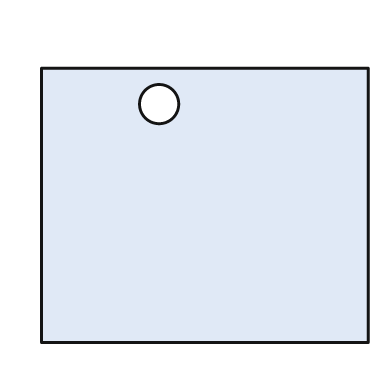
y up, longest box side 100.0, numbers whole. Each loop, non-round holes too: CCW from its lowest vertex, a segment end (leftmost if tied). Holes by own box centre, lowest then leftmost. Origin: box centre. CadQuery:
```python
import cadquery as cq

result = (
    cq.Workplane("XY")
    .moveTo(-50.0, -42.0)
    .lineTo(50.0, -42.0)
    .lineTo(50.0, 42.0)
    .lineTo(-50.0, 42.0)
    .close()
    .moveTo(-14.0, 31.0)
    .circle(6.0)
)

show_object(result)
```